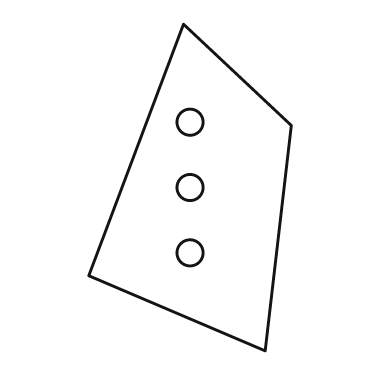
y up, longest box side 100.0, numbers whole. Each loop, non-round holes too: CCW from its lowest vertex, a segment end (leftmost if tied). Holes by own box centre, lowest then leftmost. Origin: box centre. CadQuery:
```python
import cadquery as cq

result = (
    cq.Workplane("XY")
    .moveTo(23.0, -50.0)
    .lineTo(31.0, 19.0)
    .lineTo(-2.0, 50.0)
    .lineTo(-31.0, -27.0)
    .close()
    .moveTo(0.0, -20.0)
    .circle(4.0)
    .moveTo(0.0, 0.0)
    .circle(4.0)
    .moveTo(0.0, 20.0)
    .circle(4.0)
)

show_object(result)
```